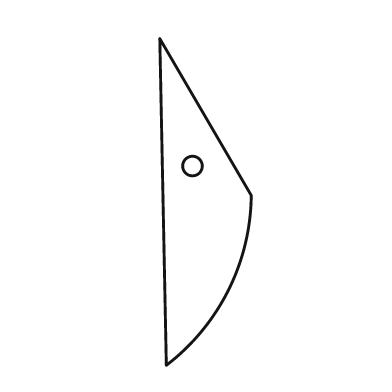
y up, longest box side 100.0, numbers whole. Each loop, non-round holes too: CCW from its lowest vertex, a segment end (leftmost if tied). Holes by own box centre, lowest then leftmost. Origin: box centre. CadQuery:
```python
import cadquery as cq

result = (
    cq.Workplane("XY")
    .moveTo(-12.0, -50.0)
    .threePointArc((7.0, -27.0), (14.0, 2.0))
    .lineTo(-14.0, 50.0)
    .close()
    .moveTo(-4.0, 11.0)
    .circle(3.0)
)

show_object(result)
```